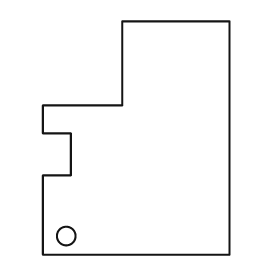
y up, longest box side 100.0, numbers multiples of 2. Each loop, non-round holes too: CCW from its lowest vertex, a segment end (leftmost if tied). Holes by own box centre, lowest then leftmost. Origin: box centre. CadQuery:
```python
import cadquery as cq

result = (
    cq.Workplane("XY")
    .moveTo(-40.0, -50.0)
    .lineTo(40.0, -50.0)
    .lineTo(40.0, 50.0)
    .lineTo(-6.0, 50.0)
    .lineTo(-6.0, 14.0)
    .lineTo(-40.0, 14.0)
    .lineTo(-40.0, 2.0)
    .lineTo(-28.0, 2.0)
    .lineTo(-28.0, -16.0)
    .lineTo(-40.0, -16.0)
    .close()
    .moveTo(-30.0, -42.0)
    .circle(4.0)
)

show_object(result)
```